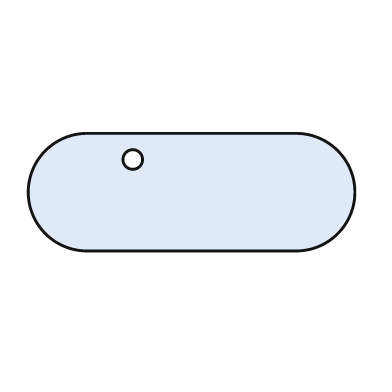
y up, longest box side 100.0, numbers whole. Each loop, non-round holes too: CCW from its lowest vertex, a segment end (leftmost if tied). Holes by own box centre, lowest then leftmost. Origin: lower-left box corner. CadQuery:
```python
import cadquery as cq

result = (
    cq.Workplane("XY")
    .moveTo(18.0, 0.0)
    .lineTo(82.0, 0.0)
    .threePointArc((100.0, 18.0), (82.0, 36.0))
    .lineTo(18.0, 36.0)
    .threePointArc((0.0, 18.0), (18.0, 0.0))
    .close()
    .moveTo(32.0, 28.0)
    .circle(3.0)
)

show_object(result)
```